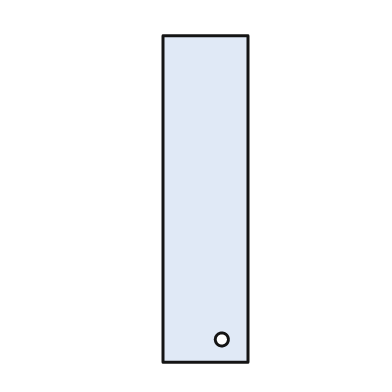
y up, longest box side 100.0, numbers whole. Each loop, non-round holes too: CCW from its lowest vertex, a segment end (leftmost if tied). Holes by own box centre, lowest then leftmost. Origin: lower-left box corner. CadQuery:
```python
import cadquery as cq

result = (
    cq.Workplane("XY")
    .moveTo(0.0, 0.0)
    .lineTo(26.0, 0.0)
    .lineTo(26.0, 100.0)
    .lineTo(0.0, 100.0)
    .close()
    .moveTo(18.0, 7.0)
    .circle(2.0)
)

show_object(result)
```